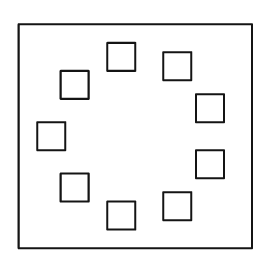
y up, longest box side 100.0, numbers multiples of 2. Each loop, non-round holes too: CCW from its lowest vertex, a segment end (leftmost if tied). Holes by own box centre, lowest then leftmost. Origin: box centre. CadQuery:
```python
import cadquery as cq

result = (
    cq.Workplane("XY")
    .moveTo(-50.0, -48.0)
    .lineTo(50.0, -48.0)
    .lineTo(50.0, 48.0)
    .lineTo(-50.0, 48.0)
    .close()
    .moveTo(-12.0, -40.0)
    .lineTo(0.0, -40.0)
    .lineTo(0.0, -28.0)
    .lineTo(-12.0, -28.0)
    .close()
    .moveTo(12.0, -36.0)
    .lineTo(24.0, -36.0)
    .lineTo(24.0, -24.0)
    .lineTo(12.0, -24.0)
    .close()
    .moveTo(-32.0, -28.0)
    .lineTo(-20.0, -28.0)
    .lineTo(-20.0, -16.0)
    .lineTo(-32.0, -16.0)
    .close()
    .moveTo(26.0, -18.0)
    .lineTo(38.0, -18.0)
    .lineTo(38.0, -6.0)
    .lineTo(26.0, -6.0)
    .close()
    .moveTo(-42.0, -6.0)
    .lineTo(-30.0, -6.0)
    .lineTo(-30.0, 6.0)
    .lineTo(-42.0, 6.0)
    .close()
    .moveTo(26.0, 6.0)
    .lineTo(38.0, 6.0)
    .lineTo(38.0, 18.0)
    .lineTo(26.0, 18.0)
    .close()
    .moveTo(-32.0, 16.0)
    .lineTo(-20.0, 16.0)
    .lineTo(-20.0, 28.0)
    .lineTo(-32.0, 28.0)
    .close()
    .moveTo(12.0, 24.0)
    .lineTo(24.0, 24.0)
    .lineTo(24.0, 36.0)
    .lineTo(12.0, 36.0)
    .close()
    .moveTo(-12.0, 28.0)
    .lineTo(0.0, 28.0)
    .lineTo(0.0, 40.0)
    .lineTo(-12.0, 40.0)
    .close()
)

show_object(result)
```